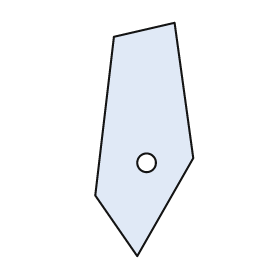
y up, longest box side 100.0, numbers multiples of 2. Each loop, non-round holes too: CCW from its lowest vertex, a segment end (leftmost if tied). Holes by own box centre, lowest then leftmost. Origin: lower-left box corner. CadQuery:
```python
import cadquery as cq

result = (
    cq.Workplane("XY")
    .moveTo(18.0, 0.0)
    .lineTo(42.0, 42.0)
    .lineTo(34.0, 100.0)
    .lineTo(8.0, 94.0)
    .lineTo(0.0, 26.0)
    .close()
    .moveTo(22.0, 40.0)
    .circle(4.0)
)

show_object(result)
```